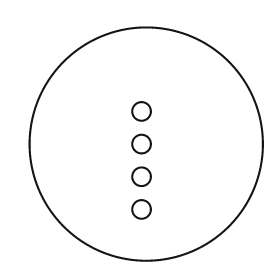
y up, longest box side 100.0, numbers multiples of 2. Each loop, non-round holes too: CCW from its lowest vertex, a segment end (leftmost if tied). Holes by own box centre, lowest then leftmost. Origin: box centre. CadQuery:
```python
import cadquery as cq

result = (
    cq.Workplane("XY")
    .moveTo(0.0, 0.0)
    .circle(50.0)
    .moveTo(-2.0, -28.0)
    .circle(4.0)
    .moveTo(-2.0, -14.0)
    .circle(4.0)
    .moveTo(-2.0, 0.0)
    .circle(4.0)
    .moveTo(-2.0, 14.0)
    .circle(4.0)
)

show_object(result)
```